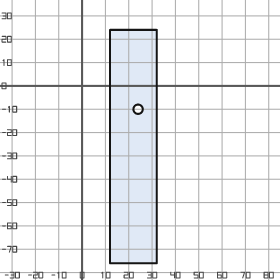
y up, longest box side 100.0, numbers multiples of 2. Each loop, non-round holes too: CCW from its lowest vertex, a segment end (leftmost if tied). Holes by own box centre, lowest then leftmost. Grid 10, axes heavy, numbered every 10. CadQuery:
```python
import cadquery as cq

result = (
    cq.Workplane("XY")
    .moveTo(12.0, -76.0)
    .lineTo(32.0, -76.0)
    .lineTo(32.0, 24.0)
    .lineTo(12.0, 24.0)
    .close()
    .moveTo(24.0, -10.0)
    .circle(2.0)
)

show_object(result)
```